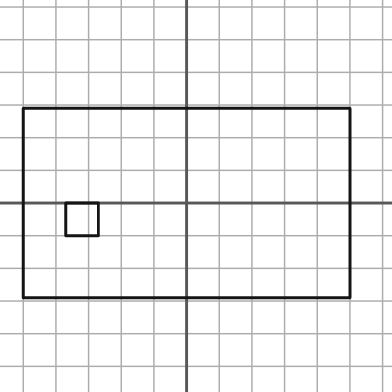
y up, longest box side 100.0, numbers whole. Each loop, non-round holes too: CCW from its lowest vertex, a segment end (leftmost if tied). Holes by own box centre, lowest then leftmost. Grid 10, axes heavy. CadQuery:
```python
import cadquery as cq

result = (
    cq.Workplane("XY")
    .moveTo(-50.0, -29.0)
    .lineTo(50.0, -29.0)
    .lineTo(50.0, 29.0)
    .lineTo(-50.0, 29.0)
    .close()
    .moveTo(-37.0, -10.0)
    .lineTo(-27.0, -10.0)
    .lineTo(-27.0, 0.0)
    .lineTo(-37.0, 0.0)
    .close()
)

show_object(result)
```